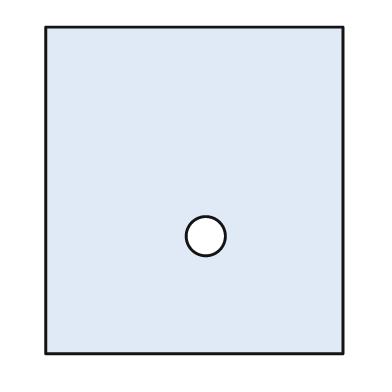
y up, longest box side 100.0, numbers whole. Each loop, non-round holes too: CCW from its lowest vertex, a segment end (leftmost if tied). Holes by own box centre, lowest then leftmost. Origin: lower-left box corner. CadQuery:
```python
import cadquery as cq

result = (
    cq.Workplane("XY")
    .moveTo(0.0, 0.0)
    .lineTo(91.0, 0.0)
    .lineTo(91.0, 100.0)
    .lineTo(0.0, 100.0)
    .close()
    .moveTo(49.0, 36.0)
    .circle(6.0)
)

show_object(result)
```